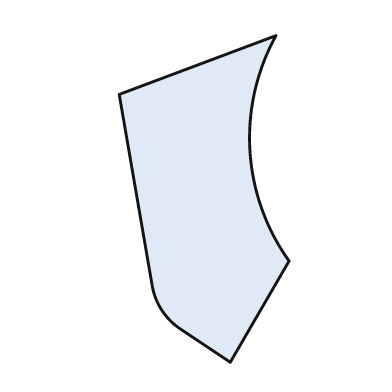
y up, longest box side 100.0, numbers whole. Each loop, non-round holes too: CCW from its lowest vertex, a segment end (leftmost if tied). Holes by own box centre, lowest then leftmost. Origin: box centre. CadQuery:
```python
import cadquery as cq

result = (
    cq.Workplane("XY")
    .moveTo(8.0, -50.0)
    .lineTo(26.0, -19.0)
    .threePointArc((14.0, 15.0), (22.0, 50.0))
    .lineTo(-26.0, 32.0)
    .lineTo(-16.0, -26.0)
    .threePointArc((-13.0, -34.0), (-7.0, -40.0))
    .close()
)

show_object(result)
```